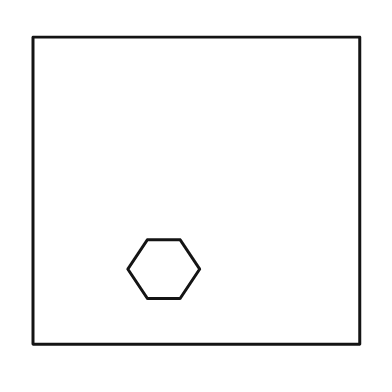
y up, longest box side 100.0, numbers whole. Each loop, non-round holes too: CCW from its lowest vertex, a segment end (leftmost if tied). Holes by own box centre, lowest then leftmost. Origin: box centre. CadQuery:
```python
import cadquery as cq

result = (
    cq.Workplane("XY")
    .moveTo(-50.0, -47.0)
    .lineTo(50.0, -47.0)
    .lineTo(50.0, 47.0)
    .lineTo(-50.0, 47.0)
    .close()
    .moveTo(-15.0, -33.0)
    .lineTo(-5.0, -33.0)
    .lineTo(1.0, -24.0)
    .lineTo(-5.0, -15.0)
    .lineTo(-15.0, -15.0)
    .lineTo(-21.0, -24.0)
    .close()
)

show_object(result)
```